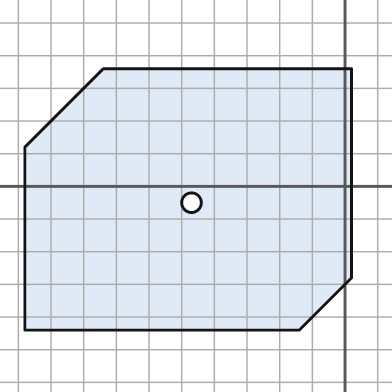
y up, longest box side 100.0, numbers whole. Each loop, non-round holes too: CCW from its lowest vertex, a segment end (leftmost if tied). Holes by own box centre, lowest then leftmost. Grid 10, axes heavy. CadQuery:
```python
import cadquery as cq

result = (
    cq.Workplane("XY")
    .moveTo(-98.0, -44.0)
    .lineTo(-14.0, -44.0)
    .lineTo(2.0, -28.0)
    .lineTo(2.0, 36.0)
    .lineTo(-74.0, 36.0)
    .lineTo(-98.0, 12.0)
    .close()
    .moveTo(-47.0, -5.0)
    .circle(3.0)
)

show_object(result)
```